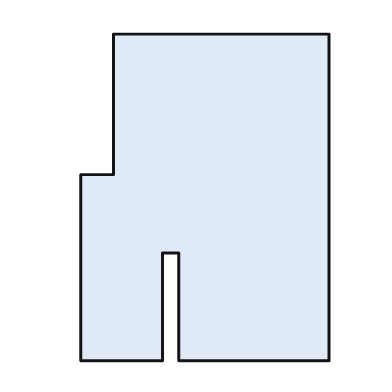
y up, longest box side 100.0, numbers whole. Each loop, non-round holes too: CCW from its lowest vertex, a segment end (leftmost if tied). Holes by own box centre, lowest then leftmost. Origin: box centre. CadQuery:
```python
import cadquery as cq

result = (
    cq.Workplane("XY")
    .moveTo(-38.0, -50.0)
    .lineTo(-13.0, -50.0)
    .lineTo(-13.0, -17.0)
    .lineTo(-8.0, -17.0)
    .lineTo(-8.0, -50.0)
    .lineTo(38.0, -50.0)
    .lineTo(38.0, 50.0)
    .lineTo(-28.0, 50.0)
    .lineTo(-28.0, 7.0)
    .lineTo(-38.0, 7.0)
    .close()
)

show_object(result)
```